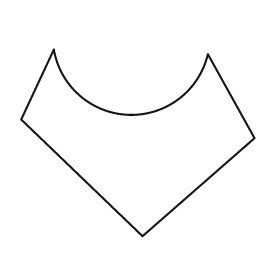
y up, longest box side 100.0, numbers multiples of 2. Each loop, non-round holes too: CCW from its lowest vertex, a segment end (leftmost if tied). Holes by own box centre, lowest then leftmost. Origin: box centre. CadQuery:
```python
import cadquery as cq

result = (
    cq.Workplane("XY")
    .moveTo(2.0, -40.0)
    .lineTo(50.0, 2.0)
    .lineTo(30.0, 38.0)
    .threePointArc((-4.0, 12.0), (-36.0, 40.0))
    .lineTo(-50.0, 10.0)
    .close()
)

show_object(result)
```